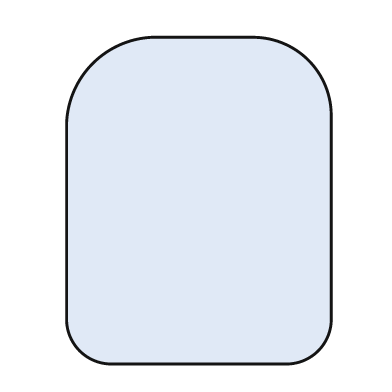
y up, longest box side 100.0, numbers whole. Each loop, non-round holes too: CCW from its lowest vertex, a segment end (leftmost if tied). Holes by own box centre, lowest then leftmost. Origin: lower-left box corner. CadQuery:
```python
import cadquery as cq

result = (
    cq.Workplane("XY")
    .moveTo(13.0, 0.0)
    .lineTo(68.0, 0.0)
    .threePointArc((77.0, 4.0), (81.0, 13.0))
    .lineTo(81.0, 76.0)
    .threePointArc((74.0, 93.0), (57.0, 100.0))
    .lineTo(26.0, 100.0)
    .threePointArc((8.0, 92.0), (0.0, 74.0))
    .lineTo(0.0, 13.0)
    .threePointArc((4.0, 4.0), (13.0, 0.0))
    .close()
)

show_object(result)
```